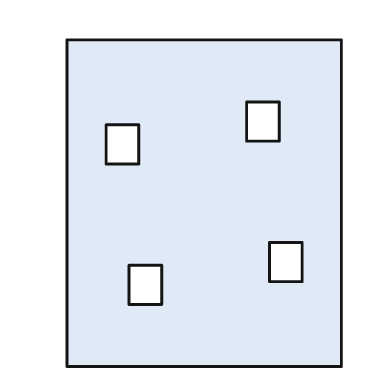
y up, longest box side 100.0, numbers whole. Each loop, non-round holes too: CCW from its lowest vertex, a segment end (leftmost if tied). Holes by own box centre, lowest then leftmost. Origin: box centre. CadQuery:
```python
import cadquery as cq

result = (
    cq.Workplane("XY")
    .moveTo(-42.0, -50.0)
    .lineTo(42.0, -50.0)
    .lineTo(42.0, 50.0)
    .lineTo(-42.0, 50.0)
    .close()
    .moveTo(-23.0, -31.0)
    .lineTo(-13.0, -31.0)
    .lineTo(-13.0, -19.0)
    .lineTo(-23.0, -19.0)
    .close()
    .moveTo(20.0, -24.0)
    .lineTo(30.0, -24.0)
    .lineTo(30.0, -12.0)
    .lineTo(20.0, -12.0)
    .close()
    .moveTo(-30.0, 12.0)
    .lineTo(-20.0, 12.0)
    .lineTo(-20.0, 24.0)
    .lineTo(-30.0, 24.0)
    .close()
    .moveTo(13.0, 19.0)
    .lineTo(23.0, 19.0)
    .lineTo(23.0, 31.0)
    .lineTo(13.0, 31.0)
    .close()
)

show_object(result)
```